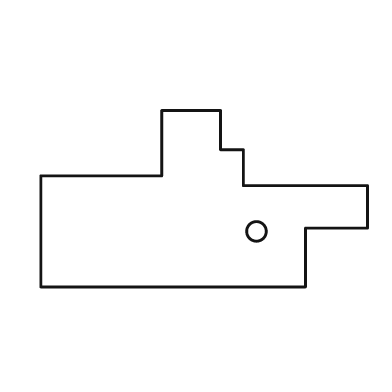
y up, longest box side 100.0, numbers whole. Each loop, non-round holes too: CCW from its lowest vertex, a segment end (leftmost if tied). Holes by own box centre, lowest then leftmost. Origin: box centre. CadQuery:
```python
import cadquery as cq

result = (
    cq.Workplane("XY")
    .moveTo(-50.0, -27.0)
    .lineTo(31.0, -27.0)
    .lineTo(31.0, -9.0)
    .lineTo(50.0, -9.0)
    .lineTo(50.0, 4.0)
    .lineTo(12.0, 4.0)
    .lineTo(12.0, 15.0)
    .lineTo(5.0, 15.0)
    .lineTo(5.0, 27.0)
    .lineTo(-13.0, 27.0)
    .lineTo(-13.0, 7.0)
    .lineTo(-50.0, 7.0)
    .close()
    .moveTo(16.0, -10.0)
    .circle(3.0)
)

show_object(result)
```